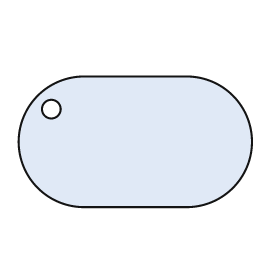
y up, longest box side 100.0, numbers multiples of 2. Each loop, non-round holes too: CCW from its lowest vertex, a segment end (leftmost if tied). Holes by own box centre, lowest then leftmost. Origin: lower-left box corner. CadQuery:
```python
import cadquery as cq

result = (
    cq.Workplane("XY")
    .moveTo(28.0, 0.0)
    .lineTo(72.0, 0.0)
    .threePointArc((100.0, 28.0), (72.0, 56.0))
    .lineTo(28.0, 56.0)
    .threePointArc((0.0, 28.0), (28.0, 0.0))
    .close()
    .moveTo(14.0, 42.0)
    .circle(4.0)
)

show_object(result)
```